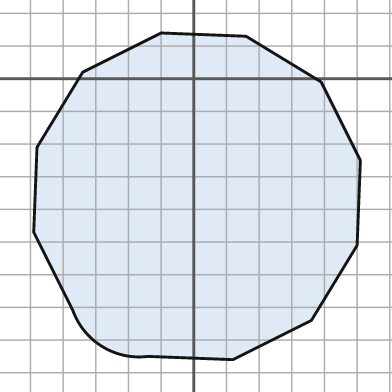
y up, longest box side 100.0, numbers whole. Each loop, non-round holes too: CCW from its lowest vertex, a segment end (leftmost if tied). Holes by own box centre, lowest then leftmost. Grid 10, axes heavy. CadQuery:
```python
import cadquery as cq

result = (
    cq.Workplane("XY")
    .moveTo(12.0, -86.0)
    .lineTo(36.0, -74.0)
    .lineTo(50.0, -51.0)
    .lineTo(51.0, -25.0)
    .lineTo(39.0, -1.0)
    .lineTo(16.0, 13.0)
    .lineTo(-10.0, 14.0)
    .lineTo(-34.0, 2.0)
    .lineTo(-48.0, -21.0)
    .lineTo(-49.0, -47.0)
    .lineTo(-37.0, -71.0)
    .threePointArc((-28.0, -82.0), (-14.0, -85.0))
    .close()
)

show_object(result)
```